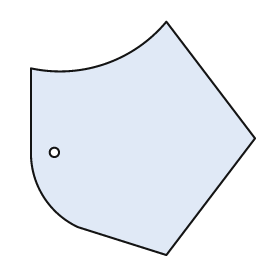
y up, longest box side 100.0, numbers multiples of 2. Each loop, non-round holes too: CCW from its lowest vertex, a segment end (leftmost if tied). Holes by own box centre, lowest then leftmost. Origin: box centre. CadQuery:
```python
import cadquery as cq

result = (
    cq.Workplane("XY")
    .moveTo(10.0, -50.0)
    .lineTo(48.0, 0.0)
    .lineTo(10.0, 50.0)
    .threePointArc((-16.0, 32.0), (-48.0, 30.0))
    .lineTo(-48.0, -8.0)
    .threePointArc((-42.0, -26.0), (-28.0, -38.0))
    .close()
    .moveTo(-38.0, -6.0)
    .circle(2.0)
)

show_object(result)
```